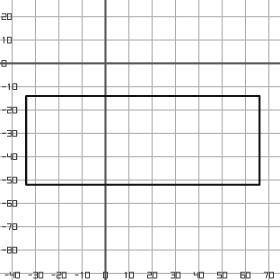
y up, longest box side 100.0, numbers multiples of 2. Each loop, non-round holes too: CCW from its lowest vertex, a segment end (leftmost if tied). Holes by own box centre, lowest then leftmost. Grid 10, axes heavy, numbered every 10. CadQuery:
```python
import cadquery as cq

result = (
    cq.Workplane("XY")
    .moveTo(-34.0, -52.0)
    .lineTo(66.0, -52.0)
    .lineTo(66.0, -14.0)
    .lineTo(-34.0, -14.0)
    .close()
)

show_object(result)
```